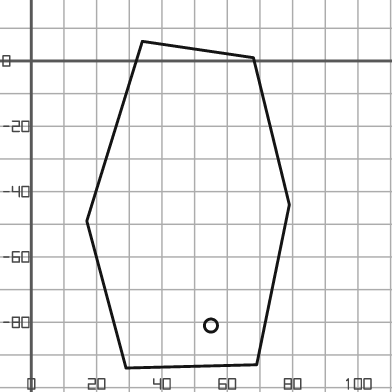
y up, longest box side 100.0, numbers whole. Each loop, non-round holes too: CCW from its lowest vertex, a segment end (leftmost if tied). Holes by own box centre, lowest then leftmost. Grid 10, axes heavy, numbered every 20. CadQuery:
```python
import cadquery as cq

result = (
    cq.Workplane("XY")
    .moveTo(29.0, -94.0)
    .lineTo(69.0, -93.0)
    .lineTo(79.0, -44.0)
    .lineTo(68.0, 1.0)
    .lineTo(34.0, 6.0)
    .lineTo(17.0, -49.0)
    .close()
    .moveTo(55.0, -81.0)
    .circle(2.0)
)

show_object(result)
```